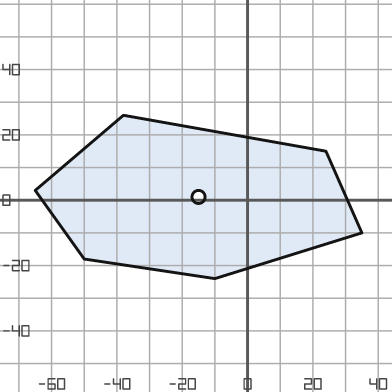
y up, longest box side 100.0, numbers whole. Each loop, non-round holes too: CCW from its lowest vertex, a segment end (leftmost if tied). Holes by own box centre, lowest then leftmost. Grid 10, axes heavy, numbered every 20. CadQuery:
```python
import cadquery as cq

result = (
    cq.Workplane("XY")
    .moveTo(-10.0, -24.0)
    .lineTo(35.0, -10.0)
    .lineTo(24.0, 15.0)
    .lineTo(-38.0, 26.0)
    .lineTo(-65.0, 3.0)
    .lineTo(-50.0, -18.0)
    .close()
    .moveTo(-15.0, 1.0)
    .circle(2.0)
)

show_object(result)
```